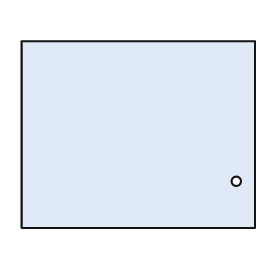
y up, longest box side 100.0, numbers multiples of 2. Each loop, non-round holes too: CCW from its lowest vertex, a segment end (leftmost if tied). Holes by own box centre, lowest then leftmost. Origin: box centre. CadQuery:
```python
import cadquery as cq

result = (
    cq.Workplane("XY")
    .moveTo(-50.0, -40.0)
    .lineTo(50.0, -40.0)
    .lineTo(50.0, 40.0)
    .lineTo(-50.0, 40.0)
    .close()
    .moveTo(42.0, -20.0)
    .circle(2.0)
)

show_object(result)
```